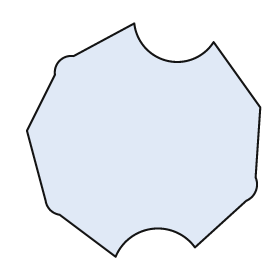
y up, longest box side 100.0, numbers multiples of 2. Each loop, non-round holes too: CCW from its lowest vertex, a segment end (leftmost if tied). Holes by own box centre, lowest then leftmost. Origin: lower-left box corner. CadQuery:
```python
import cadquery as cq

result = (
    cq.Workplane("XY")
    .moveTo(38.0, 0.0)
    .threePointArc((54.0, 12.0), (72.0, 4.0))
    .lineTo(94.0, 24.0)
    .threePointArc((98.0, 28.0), (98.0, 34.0))
    .lineTo(100.0, 64.0)
    .lineTo(80.0, 92.0)
    .threePointArc((60.0, 84.0), (46.0, 100.0))
    .lineTo(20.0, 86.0)
    .threePointArc((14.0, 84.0), (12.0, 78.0))
    .lineTo(0.0, 54.0)
    .lineTo(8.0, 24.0)
    .threePointArc((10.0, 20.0), (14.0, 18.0))
    .close()
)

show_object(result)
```